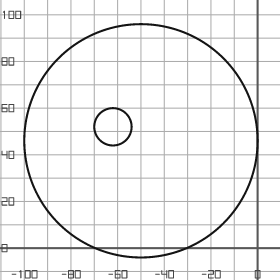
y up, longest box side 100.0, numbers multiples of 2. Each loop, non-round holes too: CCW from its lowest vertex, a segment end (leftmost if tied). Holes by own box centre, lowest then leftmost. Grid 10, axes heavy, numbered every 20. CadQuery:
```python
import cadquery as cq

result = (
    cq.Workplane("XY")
    .moveTo(-50.0, 46.0)
    .circle(50.0)
    .moveTo(-62.0, 52.0)
    .circle(8.0)
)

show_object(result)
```